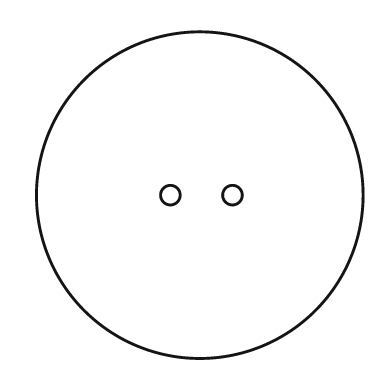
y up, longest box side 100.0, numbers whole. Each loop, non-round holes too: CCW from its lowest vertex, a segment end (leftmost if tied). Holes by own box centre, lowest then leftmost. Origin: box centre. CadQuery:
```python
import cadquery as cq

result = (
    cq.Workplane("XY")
    .moveTo(0.0, 0.0)
    .circle(50.0)
    .moveTo(-9.0, 0.0)
    .circle(3.0)
    .moveTo(10.0, 0.0)
    .circle(3.0)
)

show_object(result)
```